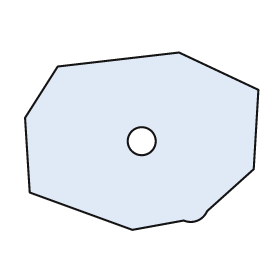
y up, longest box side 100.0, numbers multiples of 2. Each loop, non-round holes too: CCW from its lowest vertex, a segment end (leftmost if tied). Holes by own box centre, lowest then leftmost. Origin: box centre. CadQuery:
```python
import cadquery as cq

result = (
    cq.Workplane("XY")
    .moveTo(-4.0, -38.0)
    .lineTo(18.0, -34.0)
    .threePointArc((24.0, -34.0), (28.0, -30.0))
    .lineTo(48.0, -12.0)
    .lineTo(50.0, 22.0)
    .lineTo(16.0, 38.0)
    .lineTo(-36.0, 32.0)
    .lineTo(-50.0, 10.0)
    .lineTo(-48.0, -22.0)
    .close()
    .moveTo(0.0, 0.0)
    .circle(6.0)
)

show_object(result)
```